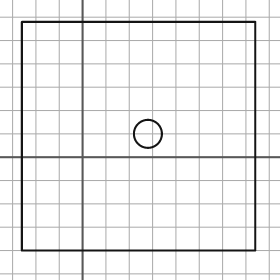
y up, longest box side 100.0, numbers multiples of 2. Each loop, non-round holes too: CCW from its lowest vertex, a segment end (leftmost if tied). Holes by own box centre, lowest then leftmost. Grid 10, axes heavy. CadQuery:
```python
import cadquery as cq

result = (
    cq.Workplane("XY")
    .moveTo(-26.0, -40.0)
    .lineTo(74.0, -40.0)
    .lineTo(74.0, 58.0)
    .lineTo(-26.0, 58.0)
    .close()
    .moveTo(28.0, 10.0)
    .circle(6.0)
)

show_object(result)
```